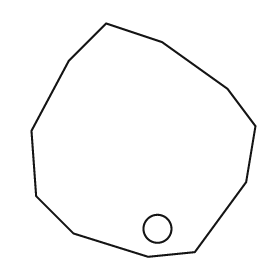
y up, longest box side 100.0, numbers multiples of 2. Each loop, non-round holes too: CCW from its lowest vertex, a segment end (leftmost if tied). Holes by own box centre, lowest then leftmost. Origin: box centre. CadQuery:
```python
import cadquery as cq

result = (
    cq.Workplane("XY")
    .moveTo(2.0, -50.0)
    .lineTo(22.0, -48.0)
    .lineTo(44.0, -18.0)
    .lineTo(48.0, 6.0)
    .lineTo(36.0, 22.0)
    .lineTo(8.0, 42.0)
    .lineTo(-16.0, 50.0)
    .lineTo(-32.0, 34.0)
    .lineTo(-48.0, 4.0)
    .lineTo(-46.0, -24.0)
    .lineTo(-30.0, -40.0)
    .close()
    .moveTo(6.0, -38.0)
    .circle(6.0)
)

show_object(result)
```